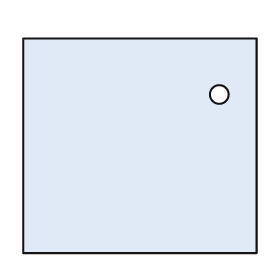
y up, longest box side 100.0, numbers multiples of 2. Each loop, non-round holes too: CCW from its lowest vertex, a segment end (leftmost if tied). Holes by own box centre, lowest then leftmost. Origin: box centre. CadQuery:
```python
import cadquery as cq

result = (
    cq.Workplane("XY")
    .moveTo(-50.0, -46.0)
    .lineTo(50.0, -46.0)
    .lineTo(50.0, 46.0)
    .lineTo(-50.0, 46.0)
    .close()
    .moveTo(34.0, 22.0)
    .circle(4.0)
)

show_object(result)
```